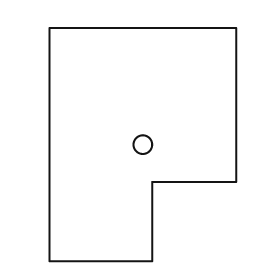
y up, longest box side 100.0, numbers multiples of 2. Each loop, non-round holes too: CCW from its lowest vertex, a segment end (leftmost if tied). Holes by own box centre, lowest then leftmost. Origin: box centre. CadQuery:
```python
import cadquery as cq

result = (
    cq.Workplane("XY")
    .moveTo(-40.0, -50.0)
    .lineTo(4.0, -50.0)
    .lineTo(4.0, -16.0)
    .lineTo(40.0, -16.0)
    .lineTo(40.0, 50.0)
    .lineTo(-40.0, 50.0)
    .close()
    .moveTo(0.0, 0.0)
    .circle(4.0)
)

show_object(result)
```